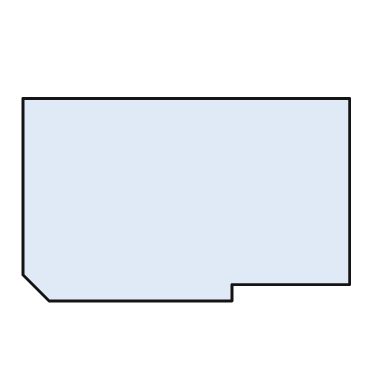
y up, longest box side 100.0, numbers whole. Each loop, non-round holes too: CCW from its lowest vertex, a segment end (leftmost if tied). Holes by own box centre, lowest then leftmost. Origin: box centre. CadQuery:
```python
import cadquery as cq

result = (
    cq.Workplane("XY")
    .moveTo(-42.0, -31.0)
    .lineTo(14.0, -31.0)
    .lineTo(14.0, -26.0)
    .lineTo(50.0, -26.0)
    .lineTo(50.0, 31.0)
    .lineTo(-50.0, 31.0)
    .lineTo(-50.0, -23.0)
    .close()
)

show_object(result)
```